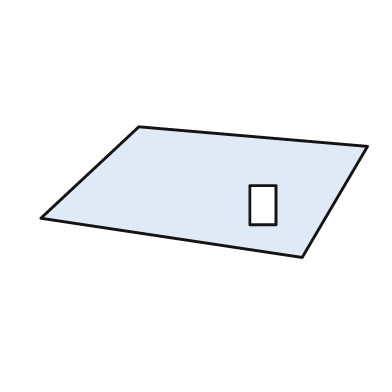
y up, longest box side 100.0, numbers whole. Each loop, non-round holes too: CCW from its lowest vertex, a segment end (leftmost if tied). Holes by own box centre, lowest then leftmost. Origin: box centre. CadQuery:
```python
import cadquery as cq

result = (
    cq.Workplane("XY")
    .moveTo(30.0, -20.0)
    .lineTo(50.0, 14.0)
    .lineTo(-20.0, 20.0)
    .lineTo(-50.0, -8.0)
    .close()
    .moveTo(14.0, -10.0)
    .lineTo(22.0, -10.0)
    .lineTo(22.0, 2.0)
    .lineTo(14.0, 2.0)
    .close()
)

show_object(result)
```